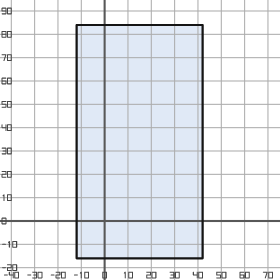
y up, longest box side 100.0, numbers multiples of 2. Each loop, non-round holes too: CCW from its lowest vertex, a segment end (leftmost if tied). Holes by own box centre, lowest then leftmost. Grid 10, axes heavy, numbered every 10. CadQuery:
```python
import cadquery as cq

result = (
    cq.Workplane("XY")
    .moveTo(-12.0, -16.0)
    .lineTo(42.0, -16.0)
    .lineTo(42.0, 84.0)
    .lineTo(-12.0, 84.0)
    .close()
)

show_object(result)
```